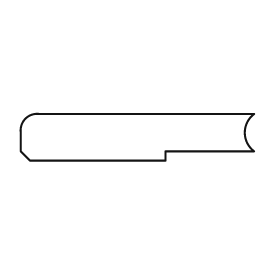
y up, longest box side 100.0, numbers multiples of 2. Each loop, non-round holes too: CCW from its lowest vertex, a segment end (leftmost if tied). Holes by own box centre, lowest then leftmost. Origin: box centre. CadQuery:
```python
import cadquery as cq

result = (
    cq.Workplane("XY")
    .moveTo(-46.0, -10.0)
    .lineTo(12.0, -10.0)
    .lineTo(12.0, -6.0)
    .lineTo(50.0, -6.0)
    .threePointArc((46.0, 2.0), (50.0, 10.0))
    .lineTo(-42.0, 10.0)
    .threePointArc((-48.0, 8.0), (-50.0, 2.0))
    .lineTo(-50.0, -6.0)
    .close()
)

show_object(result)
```